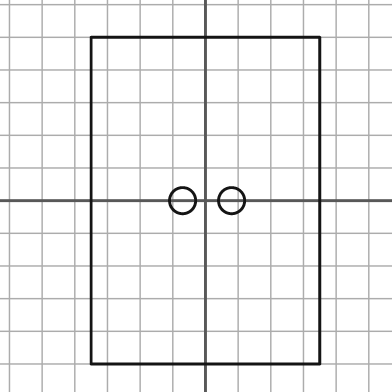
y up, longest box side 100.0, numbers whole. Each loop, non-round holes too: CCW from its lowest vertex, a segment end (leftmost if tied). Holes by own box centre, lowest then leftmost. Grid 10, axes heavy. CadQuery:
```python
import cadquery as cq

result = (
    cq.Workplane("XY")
    .moveTo(-35.0, -50.0)
    .lineTo(35.0, -50.0)
    .lineTo(35.0, 50.0)
    .lineTo(-35.0, 50.0)
    .close()
    .moveTo(-7.0, 0.0)
    .circle(4.0)
    .moveTo(8.0, 0.0)
    .circle(4.0)
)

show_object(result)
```